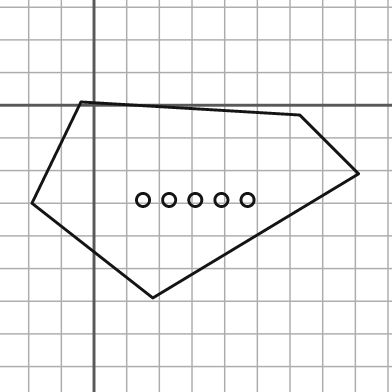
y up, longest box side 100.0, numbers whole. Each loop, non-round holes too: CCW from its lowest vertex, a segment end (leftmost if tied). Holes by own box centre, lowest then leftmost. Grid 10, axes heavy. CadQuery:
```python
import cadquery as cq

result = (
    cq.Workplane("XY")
    .moveTo(18.0, -59.0)
    .lineTo(81.0, -21.0)
    .lineTo(63.0, -3.0)
    .lineTo(-4.0, 1.0)
    .lineTo(-19.0, -30.0)
    .close()
    .moveTo(15.0, -29.0)
    .circle(2.0)
    .moveTo(23.0, -29.0)
    .circle(2.0)
    .moveTo(31.0, -29.0)
    .circle(2.0)
    .moveTo(39.0, -29.0)
    .circle(2.0)
    .moveTo(47.0, -29.0)
    .circle(2.0)
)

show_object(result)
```